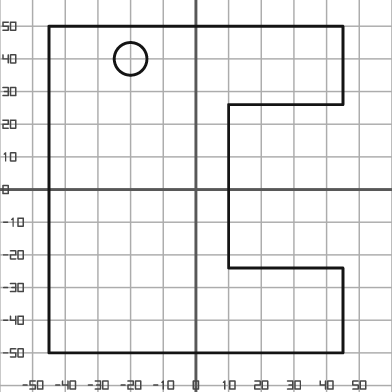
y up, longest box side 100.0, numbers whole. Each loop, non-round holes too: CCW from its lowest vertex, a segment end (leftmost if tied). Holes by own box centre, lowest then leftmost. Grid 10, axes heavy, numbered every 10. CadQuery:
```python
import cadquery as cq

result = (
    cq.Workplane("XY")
    .moveTo(-45.0, -50.0)
    .lineTo(45.0, -50.0)
    .lineTo(45.0, -24.0)
    .lineTo(10.0, -24.0)
    .lineTo(10.0, 26.0)
    .lineTo(45.0, 26.0)
    .lineTo(45.0, 50.0)
    .lineTo(-45.0, 50.0)
    .close()
    .moveTo(-20.0, 40.0)
    .circle(5.0)
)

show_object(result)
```